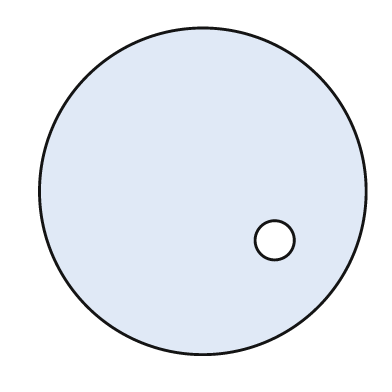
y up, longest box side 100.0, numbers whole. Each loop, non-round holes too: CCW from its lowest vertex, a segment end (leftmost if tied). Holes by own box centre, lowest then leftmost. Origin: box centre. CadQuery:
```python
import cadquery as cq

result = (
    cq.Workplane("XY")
    .moveTo(0.0, 0.0)
    .circle(50.0)
    .moveTo(22.0, -15.0)
    .circle(6.0)
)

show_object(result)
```